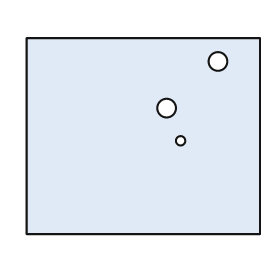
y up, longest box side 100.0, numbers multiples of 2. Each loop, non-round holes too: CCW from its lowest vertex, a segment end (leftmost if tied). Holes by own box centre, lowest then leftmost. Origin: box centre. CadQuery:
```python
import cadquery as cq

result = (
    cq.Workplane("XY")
    .moveTo(-50.0, -42.0)
    .lineTo(50.0, -42.0)
    .lineTo(50.0, 42.0)
    .lineTo(-50.0, 42.0)
    .close()
    .moveTo(16.0, -2.0)
    .circle(2.0)
    .moveTo(10.0, 12.0)
    .circle(4.0)
    .moveTo(32.0, 32.0)
    .circle(4.0)
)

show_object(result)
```